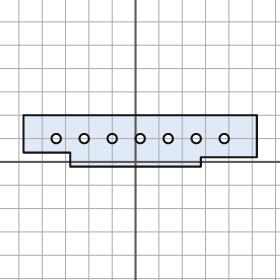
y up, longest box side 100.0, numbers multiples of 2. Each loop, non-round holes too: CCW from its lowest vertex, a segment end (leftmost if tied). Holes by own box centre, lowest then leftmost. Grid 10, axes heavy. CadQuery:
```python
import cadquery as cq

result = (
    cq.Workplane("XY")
    .moveTo(-28.0, -2.0)
    .lineTo(28.0, -2.0)
    .lineTo(28.0, 2.0)
    .lineTo(52.0, 2.0)
    .lineTo(52.0, 20.0)
    .lineTo(-48.0, 20.0)
    .lineTo(-48.0, 4.0)
    .lineTo(-28.0, 4.0)
    .close()
    .moveTo(-34.0, 10.0)
    .circle(2.0)
    .moveTo(-22.0, 10.0)
    .circle(2.0)
    .moveTo(-10.0, 10.0)
    .circle(2.0)
    .moveTo(2.0, 10.0)
    .circle(2.0)
    .moveTo(14.0, 10.0)
    .circle(2.0)
    .moveTo(26.0, 10.0)
    .circle(2.0)
    .moveTo(38.0, 10.0)
    .circle(2.0)
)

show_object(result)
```